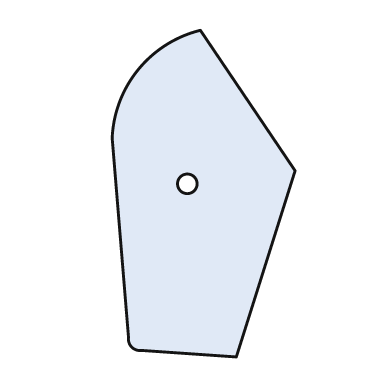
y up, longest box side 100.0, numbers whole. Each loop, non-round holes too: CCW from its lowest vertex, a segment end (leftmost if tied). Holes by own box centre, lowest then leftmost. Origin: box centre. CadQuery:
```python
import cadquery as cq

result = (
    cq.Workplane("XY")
    .moveTo(10.0, -50.0)
    .lineTo(28.0, 7.0)
    .lineTo(-1.0, 50.0)
    .threePointArc((-20.0, 38.0), (-28.0, 17.0))
    .lineTo(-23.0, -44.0)
    .threePointArc((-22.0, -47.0), (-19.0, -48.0))
    .close()
    .moveTo(-5.0, 3.0)
    .circle(3.0)
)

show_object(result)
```